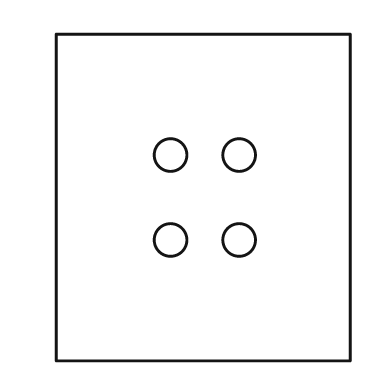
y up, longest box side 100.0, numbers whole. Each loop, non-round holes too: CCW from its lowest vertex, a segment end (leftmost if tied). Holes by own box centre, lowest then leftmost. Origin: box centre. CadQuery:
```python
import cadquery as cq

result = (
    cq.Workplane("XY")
    .moveTo(-45.0, -50.0)
    .lineTo(45.0, -50.0)
    .lineTo(45.0, 50.0)
    .lineTo(-45.0, 50.0)
    .close()
    .moveTo(-10.0, -13.0)
    .circle(5.0)
    .moveTo(11.0, -13.0)
    .circle(5.0)
    .moveTo(-10.0, 13.0)
    .circle(5.0)
    .moveTo(11.0, 13.0)
    .circle(5.0)
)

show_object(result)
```